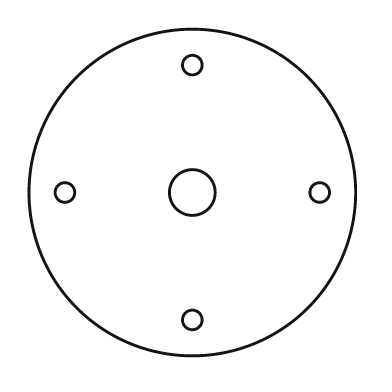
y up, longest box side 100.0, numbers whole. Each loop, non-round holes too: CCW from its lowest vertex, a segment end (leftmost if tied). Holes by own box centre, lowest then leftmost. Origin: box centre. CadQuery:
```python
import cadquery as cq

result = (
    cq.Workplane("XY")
    .moveTo(0.0, 0.0)
    .circle(50.0)
    .moveTo(0.0, -39.0)
    .circle(3.0)
    .moveTo(-39.0, 0.0)
    .circle(3.0)
    .moveTo(0.0, 0.0)
    .circle(7.0)
    .moveTo(39.0, 0.0)
    .circle(3.0)
    .moveTo(0.0, 39.0)
    .circle(3.0)
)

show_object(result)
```